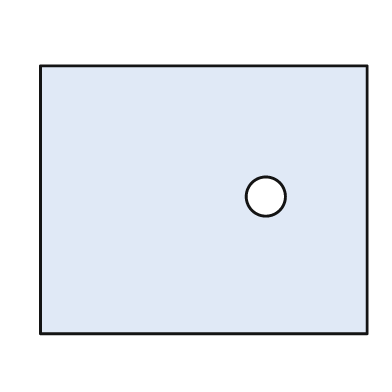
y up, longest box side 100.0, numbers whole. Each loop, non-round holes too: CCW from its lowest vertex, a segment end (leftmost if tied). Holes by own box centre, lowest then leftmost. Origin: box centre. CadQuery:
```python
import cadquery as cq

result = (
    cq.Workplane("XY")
    .moveTo(-50.0, -41.0)
    .lineTo(50.0, -41.0)
    .lineTo(50.0, 41.0)
    .lineTo(-50.0, 41.0)
    .close()
    .moveTo(19.0, 1.0)
    .circle(6.0)
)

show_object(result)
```